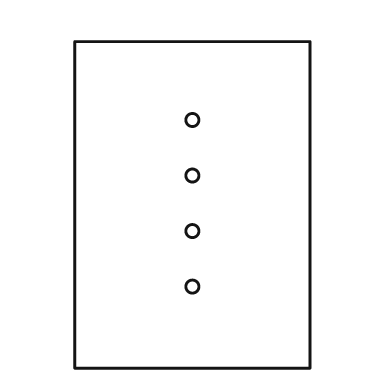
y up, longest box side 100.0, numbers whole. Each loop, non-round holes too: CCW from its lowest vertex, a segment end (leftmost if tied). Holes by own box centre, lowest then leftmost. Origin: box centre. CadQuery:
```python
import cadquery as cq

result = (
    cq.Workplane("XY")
    .moveTo(-36.0, -50.0)
    .lineTo(36.0, -50.0)
    .lineTo(36.0, 50.0)
    .lineTo(-36.0, 50.0)
    .close()
    .moveTo(0.0, -25.0)
    .circle(2.0)
    .moveTo(0.0, -8.0)
    .circle(2.0)
    .moveTo(0.0, 9.0)
    .circle(2.0)
    .moveTo(0.0, 26.0)
    .circle(2.0)
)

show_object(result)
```